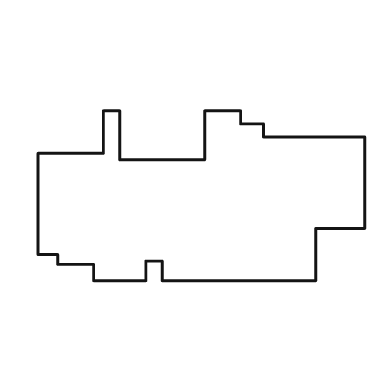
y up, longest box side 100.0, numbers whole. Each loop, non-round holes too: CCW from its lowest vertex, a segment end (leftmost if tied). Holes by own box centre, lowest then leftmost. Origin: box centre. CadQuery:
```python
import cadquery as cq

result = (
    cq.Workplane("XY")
    .moveTo(-33.0, -26.0)
    .lineTo(-17.0, -26.0)
    .lineTo(-17.0, -20.0)
    .lineTo(-12.0, -20.0)
    .lineTo(-12.0, -26.0)
    .lineTo(35.0, -26.0)
    .lineTo(35.0, -10.0)
    .lineTo(50.0, -10.0)
    .lineTo(50.0, 18.0)
    .lineTo(19.0, 18.0)
    .lineTo(19.0, 22.0)
    .lineTo(12.0, 22.0)
    .lineTo(12.0, 26.0)
    .lineTo(1.0, 26.0)
    .lineTo(1.0, 11.0)
    .lineTo(-25.0, 11.0)
    .lineTo(-25.0, 26.0)
    .lineTo(-30.0, 26.0)
    .lineTo(-30.0, 13.0)
    .lineTo(-50.0, 13.0)
    .lineTo(-50.0, -18.0)
    .lineTo(-44.0, -18.0)
    .lineTo(-44.0, -21.0)
    .lineTo(-33.0, -21.0)
    .close()
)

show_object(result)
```